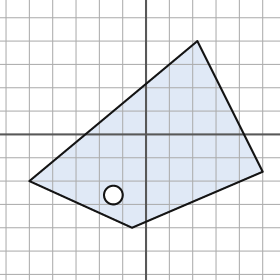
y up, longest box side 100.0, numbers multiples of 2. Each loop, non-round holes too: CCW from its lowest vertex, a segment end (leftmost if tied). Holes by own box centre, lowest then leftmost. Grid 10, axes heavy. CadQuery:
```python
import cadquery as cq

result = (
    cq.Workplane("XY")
    .moveTo(-6.0, -40.0)
    .lineTo(50.0, -16.0)
    .lineTo(22.0, 40.0)
    .lineTo(-50.0, -20.0)
    .close()
    .moveTo(-14.0, -26.0)
    .circle(4.0)
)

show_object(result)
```